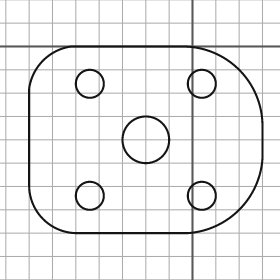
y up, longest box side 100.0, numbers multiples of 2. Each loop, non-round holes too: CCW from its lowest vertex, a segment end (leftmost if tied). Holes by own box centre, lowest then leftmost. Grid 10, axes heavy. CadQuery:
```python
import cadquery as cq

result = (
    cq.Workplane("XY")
    .moveTo(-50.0, -80.0)
    .lineTo(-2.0, -80.0)
    .threePointArc((20.0, -70.0), (30.0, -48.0))
    .lineTo(30.0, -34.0)
    .threePointArc((20.0, -10.0), (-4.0, 0.0))
    .lineTo(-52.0, 0.0)
    .threePointArc((-64.0, -6.0), (-70.0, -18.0))
    .lineTo(-70.0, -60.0)
    .threePointArc((-64.0, -74.0), (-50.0, -80.0))
    .close()
    .moveTo(-44.0, -64.0)
    .circle(6.0)
    .moveTo(4.0, -64.0)
    .circle(6.0)
    .moveTo(-20.0, -40.0)
    .circle(10.0)
    .moveTo(-44.0, -16.0)
    .circle(6.0)
    .moveTo(4.0, -16.0)
    .circle(6.0)
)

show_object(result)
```